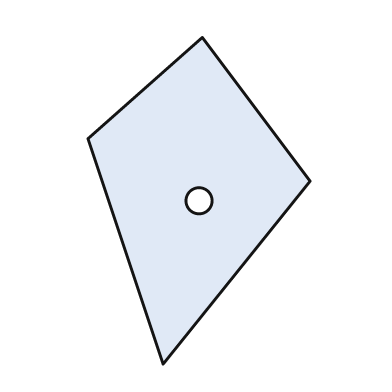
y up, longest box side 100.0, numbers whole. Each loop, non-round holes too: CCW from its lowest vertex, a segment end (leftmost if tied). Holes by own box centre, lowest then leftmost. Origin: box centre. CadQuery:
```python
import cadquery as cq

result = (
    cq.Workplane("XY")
    .moveTo(-11.0, -50.0)
    .lineTo(34.0, 6.0)
    .lineTo(1.0, 50.0)
    .lineTo(-34.0, 19.0)
    .close()
    .moveTo(0.0, 0.0)
    .circle(4.0)
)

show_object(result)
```